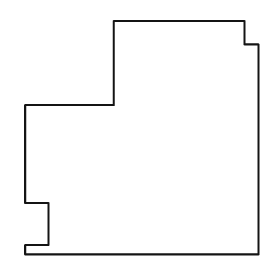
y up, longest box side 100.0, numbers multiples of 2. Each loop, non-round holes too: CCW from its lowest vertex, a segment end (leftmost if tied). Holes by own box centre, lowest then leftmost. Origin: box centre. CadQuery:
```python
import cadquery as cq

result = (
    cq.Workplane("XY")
    .moveTo(-50.0, -50.0)
    .lineTo(50.0, -50.0)
    .lineTo(50.0, 40.0)
    .lineTo(44.0, 40.0)
    .lineTo(44.0, 50.0)
    .lineTo(-12.0, 50.0)
    .lineTo(-12.0, 14.0)
    .lineTo(-50.0, 14.0)
    .lineTo(-50.0, -28.0)
    .lineTo(-40.0, -28.0)
    .lineTo(-40.0, -46.0)
    .lineTo(-50.0, -46.0)
    .close()
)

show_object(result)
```